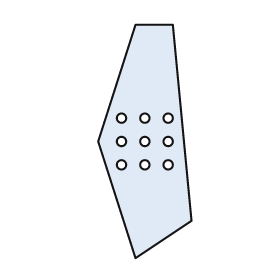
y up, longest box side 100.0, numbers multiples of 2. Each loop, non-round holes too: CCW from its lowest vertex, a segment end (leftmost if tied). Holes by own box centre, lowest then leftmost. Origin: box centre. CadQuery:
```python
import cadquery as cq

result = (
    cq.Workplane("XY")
    .moveTo(-4.0, -50.0)
    .lineTo(20.0, -34.0)
    .lineTo(12.0, 50.0)
    .lineTo(-4.0, 50.0)
    .lineTo(-20.0, 0.0)
    .close()
    .moveTo(-10.0, -10.0)
    .circle(2.0)
    .moveTo(0.0, -10.0)
    .circle(2.0)
    .moveTo(10.0, -10.0)
    .circle(2.0)
    .moveTo(-10.0, 0.0)
    .circle(2.0)
    .moveTo(0.0, 0.0)
    .circle(2.0)
    .moveTo(10.0, 0.0)
    .circle(2.0)
    .moveTo(-10.0, 10.0)
    .circle(2.0)
    .moveTo(0.0, 10.0)
    .circle(2.0)
    .moveTo(10.0, 10.0)
    .circle(2.0)
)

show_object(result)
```